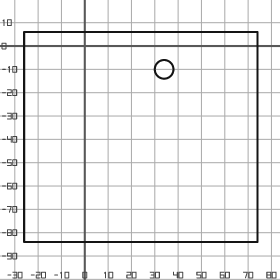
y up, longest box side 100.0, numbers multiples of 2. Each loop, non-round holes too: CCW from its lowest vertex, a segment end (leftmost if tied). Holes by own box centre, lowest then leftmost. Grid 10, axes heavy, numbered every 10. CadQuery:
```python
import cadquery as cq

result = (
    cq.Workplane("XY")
    .moveTo(-26.0, -84.0)
    .lineTo(74.0, -84.0)
    .lineTo(74.0, 6.0)
    .lineTo(-26.0, 6.0)
    .close()
    .moveTo(34.0, -10.0)
    .circle(4.0)
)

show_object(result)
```